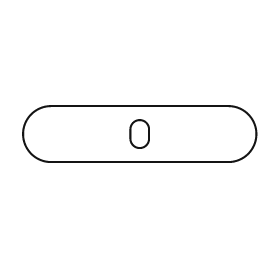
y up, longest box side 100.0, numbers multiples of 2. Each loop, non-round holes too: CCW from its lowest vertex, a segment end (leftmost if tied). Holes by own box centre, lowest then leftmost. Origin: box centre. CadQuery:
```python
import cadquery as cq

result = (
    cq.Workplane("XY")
    .moveTo(-38.0, -12.0)
    .lineTo(38.0, -12.0)
    .threePointArc((50.0, 0.0), (38.0, 12.0))
    .lineTo(-38.0, 12.0)
    .threePointArc((-50.0, 0.0), (-38.0, -12.0))
    .close()
    .moveTo(-4.0, -2.0)
    .threePointArc((0.0, -6.0), (4.0, -2.0))
    .lineTo(4.0, 2.0)
    .threePointArc((0.0, 6.0), (-4.0, 2.0))
    .close()
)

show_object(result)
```